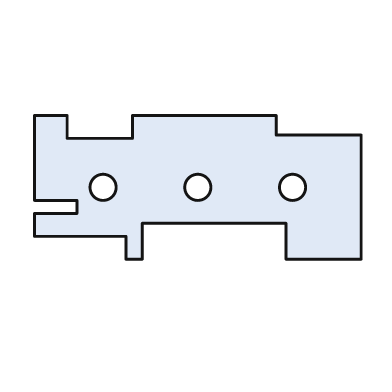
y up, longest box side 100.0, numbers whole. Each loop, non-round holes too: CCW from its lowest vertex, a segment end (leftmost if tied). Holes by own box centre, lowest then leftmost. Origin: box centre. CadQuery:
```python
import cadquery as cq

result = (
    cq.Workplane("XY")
    .moveTo(-22.0, -22.0)
    .lineTo(-17.0, -22.0)
    .lineTo(-17.0, -11.0)
    .lineTo(27.0, -11.0)
    .lineTo(27.0, -22.0)
    .lineTo(50.0, -22.0)
    .lineTo(50.0, 16.0)
    .lineTo(24.0, 16.0)
    .lineTo(24.0, 22.0)
    .lineTo(-20.0, 22.0)
    .lineTo(-20.0, 15.0)
    .lineTo(-40.0, 15.0)
    .lineTo(-40.0, 22.0)
    .lineTo(-50.0, 22.0)
    .lineTo(-50.0, -4.0)
    .lineTo(-37.0, -4.0)
    .lineTo(-37.0, -8.0)
    .lineTo(-50.0, -8.0)
    .lineTo(-50.0, -15.0)
    .lineTo(-22.0, -15.0)
    .close()
    .moveTo(-29.0, 0.0)
    .circle(4.0)
    .moveTo(0.0, 0.0)
    .circle(4.0)
    .moveTo(29.0, 0.0)
    .circle(4.0)
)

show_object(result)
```